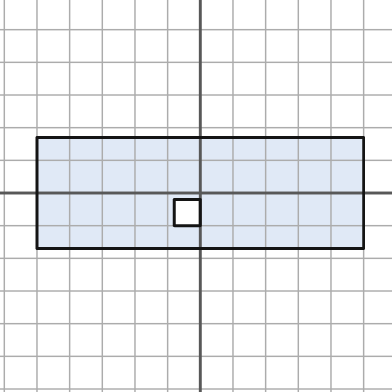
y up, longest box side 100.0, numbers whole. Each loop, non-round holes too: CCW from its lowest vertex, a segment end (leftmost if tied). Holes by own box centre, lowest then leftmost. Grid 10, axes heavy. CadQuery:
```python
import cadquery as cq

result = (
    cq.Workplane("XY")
    .moveTo(-50.0, -17.0)
    .lineTo(50.0, -17.0)
    .lineTo(50.0, 17.0)
    .lineTo(-50.0, 17.0)
    .close()
    .moveTo(-8.0, -10.0)
    .lineTo(0.0, -10.0)
    .lineTo(0.0, -2.0)
    .lineTo(-8.0, -2.0)
    .close()
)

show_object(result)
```